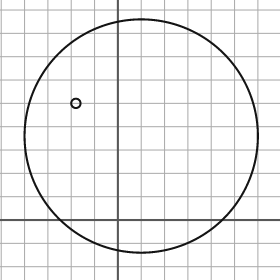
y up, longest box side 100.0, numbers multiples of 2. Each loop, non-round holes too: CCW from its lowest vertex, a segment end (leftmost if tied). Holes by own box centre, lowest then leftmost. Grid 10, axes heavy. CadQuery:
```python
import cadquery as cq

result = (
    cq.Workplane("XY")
    .moveTo(10.0, 36.0)
    .circle(50.0)
    .moveTo(-18.0, 50.0)
    .circle(2.0)
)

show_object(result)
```